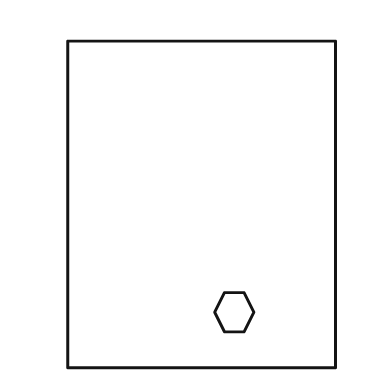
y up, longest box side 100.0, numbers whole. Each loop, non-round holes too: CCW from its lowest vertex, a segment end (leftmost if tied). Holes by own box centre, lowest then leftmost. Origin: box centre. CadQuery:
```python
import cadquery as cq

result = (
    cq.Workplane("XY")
    .moveTo(-41.0, -50.0)
    .lineTo(41.0, -50.0)
    .lineTo(41.0, 50.0)
    .lineTo(-41.0, 50.0)
    .close()
    .moveTo(7.0, -39.0)
    .lineTo(13.0, -39.0)
    .lineTo(16.0, -33.0)
    .lineTo(13.0, -27.0)
    .lineTo(7.0, -27.0)
    .lineTo(4.0, -33.0)
    .close()
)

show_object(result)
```